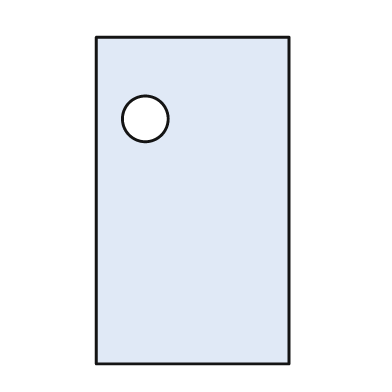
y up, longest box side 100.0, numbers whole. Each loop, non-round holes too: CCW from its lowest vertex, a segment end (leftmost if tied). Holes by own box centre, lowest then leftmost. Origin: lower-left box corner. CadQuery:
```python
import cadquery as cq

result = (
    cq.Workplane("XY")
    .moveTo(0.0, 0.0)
    .lineTo(59.0, 0.0)
    .lineTo(59.0, 100.0)
    .lineTo(0.0, 100.0)
    .close()
    .moveTo(15.0, 75.0)
    .circle(7.0)
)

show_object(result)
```